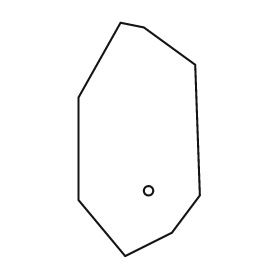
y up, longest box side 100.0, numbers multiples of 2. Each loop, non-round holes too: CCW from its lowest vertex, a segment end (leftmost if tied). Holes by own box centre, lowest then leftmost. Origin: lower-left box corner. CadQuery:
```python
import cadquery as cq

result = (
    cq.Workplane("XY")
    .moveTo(20.0, 0.0)
    .lineTo(40.0, 10.0)
    .lineTo(52.0, 26.0)
    .lineTo(50.0, 82.0)
    .lineTo(28.0, 98.0)
    .lineTo(18.0, 100.0)
    .lineTo(0.0, 68.0)
    .lineTo(0.0, 24.0)
    .close()
    .moveTo(30.0, 28.0)
    .circle(2.0)
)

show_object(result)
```